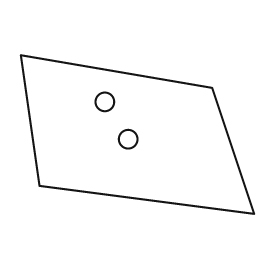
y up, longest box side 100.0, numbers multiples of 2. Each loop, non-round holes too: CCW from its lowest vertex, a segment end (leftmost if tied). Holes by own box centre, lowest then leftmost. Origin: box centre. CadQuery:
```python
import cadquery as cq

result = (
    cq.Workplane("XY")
    .moveTo(50.0, -34.0)
    .lineTo(32.0, 20.0)
    .lineTo(-50.0, 34.0)
    .lineTo(-42.0, -22.0)
    .close()
    .moveTo(-4.0, -2.0)
    .circle(4.0)
    .moveTo(-14.0, 14.0)
    .circle(4.0)
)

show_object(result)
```